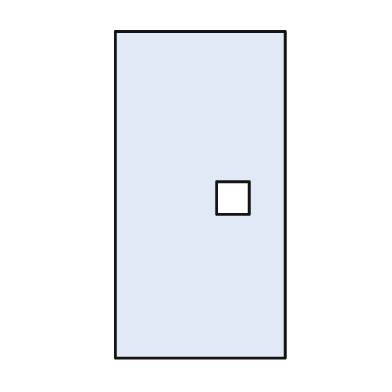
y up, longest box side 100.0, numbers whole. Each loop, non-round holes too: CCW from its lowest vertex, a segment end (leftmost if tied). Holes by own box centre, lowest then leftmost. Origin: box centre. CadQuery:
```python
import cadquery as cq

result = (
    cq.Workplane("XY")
    .moveTo(-26.0, -50.0)
    .lineTo(26.0, -50.0)
    .lineTo(26.0, 50.0)
    .lineTo(-26.0, 50.0)
    .close()
    .moveTo(5.0, -6.0)
    .lineTo(15.0, -6.0)
    .lineTo(15.0, 4.0)
    .lineTo(5.0, 4.0)
    .close()
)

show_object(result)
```